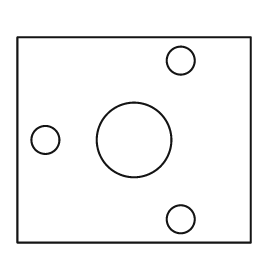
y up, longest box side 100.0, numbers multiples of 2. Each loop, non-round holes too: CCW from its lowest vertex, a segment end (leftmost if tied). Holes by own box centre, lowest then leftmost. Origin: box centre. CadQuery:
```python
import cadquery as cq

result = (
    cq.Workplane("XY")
    .moveTo(-50.0, -44.0)
    .lineTo(50.0, -44.0)
    .lineTo(50.0, 44.0)
    .lineTo(-50.0, 44.0)
    .close()
    .moveTo(20.0, -34.0)
    .circle(6.0)
    .moveTo(-38.0, 0.0)
    .circle(6.0)
    .moveTo(0.0, 0.0)
    .circle(16.0)
    .moveTo(20.0, 34.0)
    .circle(6.0)
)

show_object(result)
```